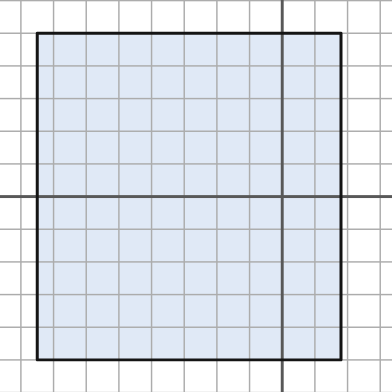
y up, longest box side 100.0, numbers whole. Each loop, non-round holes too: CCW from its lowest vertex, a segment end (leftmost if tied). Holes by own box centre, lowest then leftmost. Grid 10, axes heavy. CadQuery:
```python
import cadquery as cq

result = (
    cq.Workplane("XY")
    .moveTo(-75.0, -50.0)
    .lineTo(18.0, -50.0)
    .lineTo(18.0, 50.0)
    .lineTo(-75.0, 50.0)
    .close()
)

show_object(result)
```